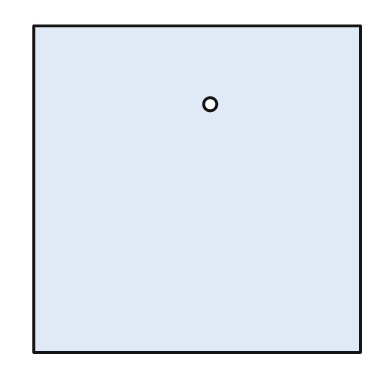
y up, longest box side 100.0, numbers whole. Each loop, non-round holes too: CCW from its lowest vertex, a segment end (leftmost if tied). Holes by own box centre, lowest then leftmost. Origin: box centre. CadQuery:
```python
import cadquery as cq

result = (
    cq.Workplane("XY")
    .moveTo(-50.0, -50.0)
    .lineTo(50.0, -50.0)
    .lineTo(50.0, 50.0)
    .lineTo(-50.0, 50.0)
    .close()
    .moveTo(4.0, 26.0)
    .circle(2.0)
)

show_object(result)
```